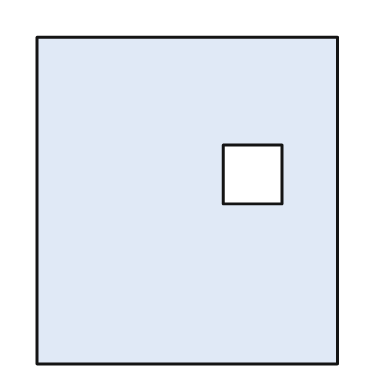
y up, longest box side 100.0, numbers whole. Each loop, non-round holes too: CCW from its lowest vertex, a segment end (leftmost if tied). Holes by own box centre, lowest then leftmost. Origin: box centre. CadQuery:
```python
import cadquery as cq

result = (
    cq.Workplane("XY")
    .moveTo(-46.0, -50.0)
    .lineTo(46.0, -50.0)
    .lineTo(46.0, 50.0)
    .lineTo(-46.0, 50.0)
    .close()
    .moveTo(11.0, -1.0)
    .lineTo(29.0, -1.0)
    .lineTo(29.0, 17.0)
    .lineTo(11.0, 17.0)
    .close()
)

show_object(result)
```